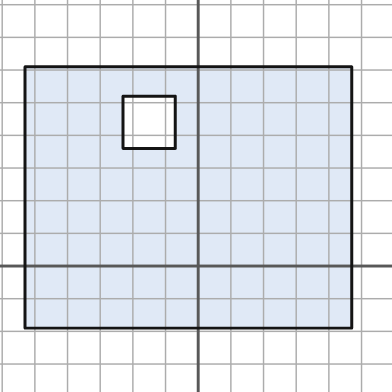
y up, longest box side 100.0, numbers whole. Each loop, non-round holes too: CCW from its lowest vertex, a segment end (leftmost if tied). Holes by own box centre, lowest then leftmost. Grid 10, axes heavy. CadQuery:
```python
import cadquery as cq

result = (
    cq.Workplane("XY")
    .moveTo(-53.0, -19.0)
    .lineTo(47.0, -19.0)
    .lineTo(47.0, 61.0)
    .lineTo(-53.0, 61.0)
    .close()
    .moveTo(-23.0, 36.0)
    .lineTo(-7.0, 36.0)
    .lineTo(-7.0, 52.0)
    .lineTo(-23.0, 52.0)
    .close()
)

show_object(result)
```